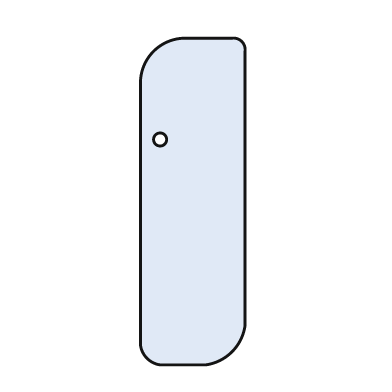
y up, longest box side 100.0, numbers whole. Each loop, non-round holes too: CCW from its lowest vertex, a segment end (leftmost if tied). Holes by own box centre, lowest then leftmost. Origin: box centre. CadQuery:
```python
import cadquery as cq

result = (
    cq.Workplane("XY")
    .moveTo(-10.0, -50.0)
    .lineTo(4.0, -50.0)
    .threePointArc((12.0, -46.0), (16.0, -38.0))
    .lineTo(16.0, 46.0)
    .threePointArc((15.0, 49.0), (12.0, 50.0))
    .lineTo(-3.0, 50.0)
    .threePointArc((-12.0, 46.0), (-16.0, 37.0))
    .lineTo(-16.0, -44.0)
    .threePointArc((-14.0, -48.0), (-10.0, -50.0))
    .close()
    .moveTo(-10.0, 19.0)
    .circle(2.0)
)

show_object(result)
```